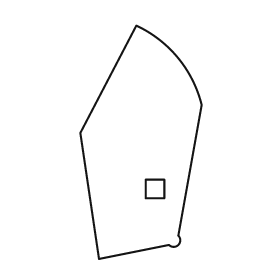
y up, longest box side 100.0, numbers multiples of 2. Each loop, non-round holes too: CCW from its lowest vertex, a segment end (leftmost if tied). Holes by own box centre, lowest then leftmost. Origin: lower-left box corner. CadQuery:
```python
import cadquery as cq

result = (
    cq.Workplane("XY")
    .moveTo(8.0, 0.0)
    .lineTo(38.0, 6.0)
    .threePointArc((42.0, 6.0), (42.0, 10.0))
    .lineTo(52.0, 66.0)
    .threePointArc((42.0, 86.0), (24.0, 100.0))
    .lineTo(0.0, 54.0)
    .close()
    .moveTo(28.0, 26.0)
    .lineTo(36.0, 26.0)
    .lineTo(36.0, 34.0)
    .lineTo(28.0, 34.0)
    .close()
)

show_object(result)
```